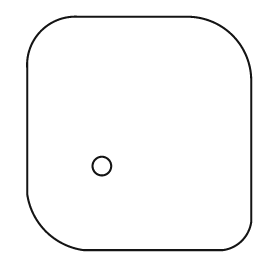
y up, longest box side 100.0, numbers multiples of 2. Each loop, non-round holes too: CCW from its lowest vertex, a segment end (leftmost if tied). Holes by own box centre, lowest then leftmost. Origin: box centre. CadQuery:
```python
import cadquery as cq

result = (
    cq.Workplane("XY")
    .moveTo(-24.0, -50.0)
    .lineTo(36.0, -50.0)
    .threePointArc((44.0, -46.0), (48.0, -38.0))
    .lineTo(48.0, 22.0)
    .threePointArc((40.0, 42.0), (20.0, 50.0))
    .lineTo(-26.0, 50.0)
    .threePointArc((-42.0, 44.0), (-48.0, 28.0))
    .lineTo(-48.0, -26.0)
    .threePointArc((-40.0, -42.0), (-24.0, -50.0))
    .close()
    .moveTo(-16.0, -14.0)
    .circle(4.0)
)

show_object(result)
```